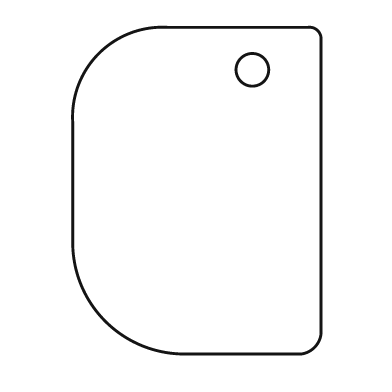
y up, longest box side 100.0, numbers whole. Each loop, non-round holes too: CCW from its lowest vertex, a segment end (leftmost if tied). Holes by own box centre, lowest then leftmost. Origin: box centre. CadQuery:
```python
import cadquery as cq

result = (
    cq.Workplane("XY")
    .moveTo(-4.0, -50.0)
    .lineTo(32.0, -50.0)
    .threePointArc((36.0, -48.0), (38.0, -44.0))
    .lineTo(38.0, 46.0)
    .threePointArc((37.0, 49.0), (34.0, 50.0))
    .lineTo(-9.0, 50.0)
    .threePointArc((-30.0, 42.0), (-38.0, 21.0))
    .lineTo(-38.0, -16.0)
    .threePointArc((-28.0, -40.0), (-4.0, -50.0))
    .close()
    .moveTo(17.0, 37.0)
    .circle(5.0)
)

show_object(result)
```